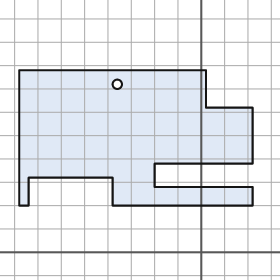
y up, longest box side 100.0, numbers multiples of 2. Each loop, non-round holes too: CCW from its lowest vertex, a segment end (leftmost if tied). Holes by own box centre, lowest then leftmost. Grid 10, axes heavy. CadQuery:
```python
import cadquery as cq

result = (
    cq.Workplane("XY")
    .moveTo(-78.0, 20.0)
    .lineTo(-74.0, 20.0)
    .lineTo(-74.0, 32.0)
    .lineTo(-38.0, 32.0)
    .lineTo(-38.0, 20.0)
    .lineTo(22.0, 20.0)
    .lineTo(22.0, 28.0)
    .lineTo(-20.0, 28.0)
    .lineTo(-20.0, 38.0)
    .lineTo(22.0, 38.0)
    .lineTo(22.0, 62.0)
    .lineTo(2.0, 62.0)
    .lineTo(2.0, 78.0)
    .lineTo(-78.0, 78.0)
    .close()
    .moveTo(-36.0, 72.0)
    .circle(2.0)
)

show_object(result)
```